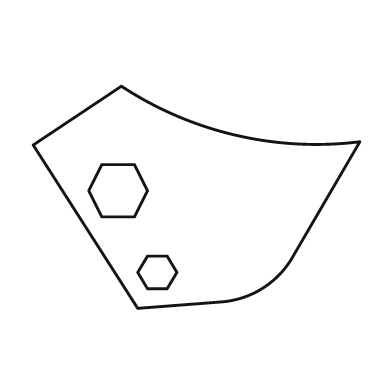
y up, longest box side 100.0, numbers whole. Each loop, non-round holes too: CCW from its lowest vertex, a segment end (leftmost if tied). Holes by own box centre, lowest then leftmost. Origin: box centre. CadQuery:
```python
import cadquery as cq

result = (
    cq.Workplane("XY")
    .moveTo(-18.0, -34.0)
    .lineTo(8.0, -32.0)
    .threePointArc((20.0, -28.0), (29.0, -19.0))
    .lineTo(50.0, 17.0)
    .threePointArc((12.0, 19.0), (-23.0, 34.0))
    .lineTo(-50.0, 16.0)
    .close()
    .moveTo(-15.0, -28.0)
    .lineTo(-9.0, -28.0)
    .lineTo(-6.0, -23.0)
    .lineTo(-9.0, -18.0)
    .lineTo(-15.0, -18.0)
    .lineTo(-18.0, -23.0)
    .close()
    .moveTo(-29.0, -6.0)
    .lineTo(-19.0, -6.0)
    .lineTo(-15.0, 2.0)
    .lineTo(-19.0, 10.0)
    .lineTo(-29.0, 10.0)
    .lineTo(-33.0, 2.0)
    .close()
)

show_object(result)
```